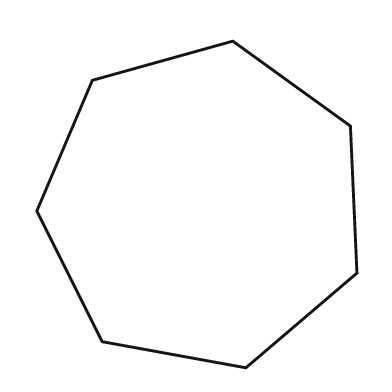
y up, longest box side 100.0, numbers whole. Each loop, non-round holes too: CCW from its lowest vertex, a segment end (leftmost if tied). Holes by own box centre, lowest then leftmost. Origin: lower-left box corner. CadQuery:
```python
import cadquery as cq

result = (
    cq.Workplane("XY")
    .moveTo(64.0, 0.0)
    .lineTo(98.0, 29.0)
    .lineTo(96.0, 74.0)
    .lineTo(60.0, 100.0)
    .lineTo(17.0, 88.0)
    .lineTo(0.0, 48.0)
    .lineTo(20.0, 8.0)
    .close()
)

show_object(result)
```